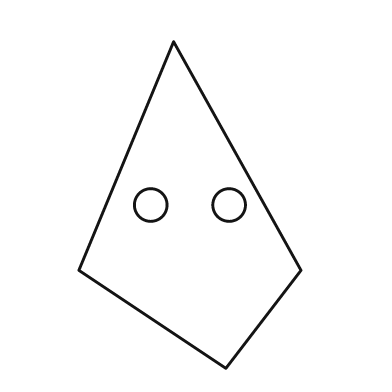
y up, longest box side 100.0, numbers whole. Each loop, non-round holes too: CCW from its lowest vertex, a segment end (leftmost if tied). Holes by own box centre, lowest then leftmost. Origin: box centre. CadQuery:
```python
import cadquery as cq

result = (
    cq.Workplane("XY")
    .moveTo(11.0, -50.0)
    .lineTo(34.0, -20.0)
    .lineTo(-5.0, 50.0)
    .lineTo(-34.0, -20.0)
    .close()
    .moveTo(-12.0, 0.0)
    .circle(5.0)
    .moveTo(12.0, 0.0)
    .circle(5.0)
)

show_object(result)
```